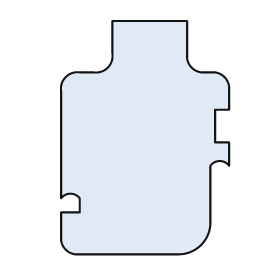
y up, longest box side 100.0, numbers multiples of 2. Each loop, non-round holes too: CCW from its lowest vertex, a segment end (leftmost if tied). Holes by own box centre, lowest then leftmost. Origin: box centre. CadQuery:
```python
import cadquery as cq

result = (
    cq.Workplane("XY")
    .moveTo(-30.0, -50.0)
    .lineTo(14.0, -50.0)
    .threePointArc((24.0, -46.0), (28.0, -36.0))
    .lineTo(28.0, -12.0)
    .threePointArc((32.0, -10.0), (36.0, -12.0))
    .lineTo(36.0, -2.0)
    .lineTo(30.0, -2.0)
    .lineTo(30.0, 12.0)
    .lineTo(36.0, 12.0)
    .lineTo(36.0, 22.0)
    .threePointArc((34.0, 26.0), (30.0, 28.0))
    .lineTo(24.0, 28.0)
    .threePointArc((20.0, 30.0), (18.0, 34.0))
    .lineTo(18.0, 50.0)
    .lineTo(-14.0, 50.0)
    .lineTo(-14.0, 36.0)
    .threePointArc((-16.0, 30.0), (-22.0, 28.0))
    .lineTo(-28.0, 28.0)
    .threePointArc((-34.0, 26.0), (-36.0, 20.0))
    .lineTo(-36.0, -26.0)
    .threePointArc((-32.0, -24.0), (-28.0, -26.0))
    .lineTo(-28.0, -32.0)
    .lineTo(-36.0, -32.0)
    .lineTo(-36.0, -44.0)
    .threePointArc((-34.0, -48.0), (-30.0, -50.0))
    .close()
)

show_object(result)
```